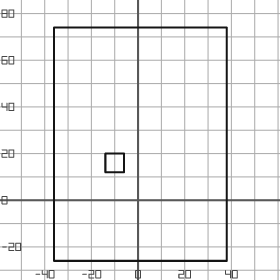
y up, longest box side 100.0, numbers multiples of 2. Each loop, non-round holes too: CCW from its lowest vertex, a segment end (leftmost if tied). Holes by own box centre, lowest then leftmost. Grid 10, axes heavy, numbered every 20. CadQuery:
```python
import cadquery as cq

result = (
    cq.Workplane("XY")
    .moveTo(-36.0, -26.0)
    .lineTo(38.0, -26.0)
    .lineTo(38.0, 74.0)
    .lineTo(-36.0, 74.0)
    .close()
    .moveTo(-14.0, 12.0)
    .lineTo(-6.0, 12.0)
    .lineTo(-6.0, 20.0)
    .lineTo(-14.0, 20.0)
    .close()
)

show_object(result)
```